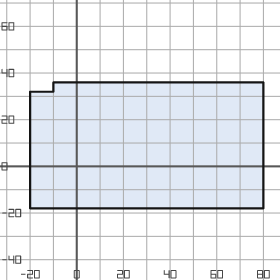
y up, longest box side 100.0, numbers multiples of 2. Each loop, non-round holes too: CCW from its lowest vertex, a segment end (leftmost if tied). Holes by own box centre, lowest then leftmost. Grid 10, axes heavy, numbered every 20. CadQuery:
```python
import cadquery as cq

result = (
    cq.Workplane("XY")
    .moveTo(-20.0, -18.0)
    .lineTo(80.0, -18.0)
    .lineTo(80.0, 36.0)
    .lineTo(-10.0, 36.0)
    .lineTo(-10.0, 32.0)
    .lineTo(-20.0, 32.0)
    .close()
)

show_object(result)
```